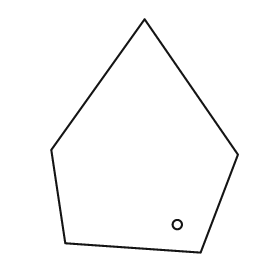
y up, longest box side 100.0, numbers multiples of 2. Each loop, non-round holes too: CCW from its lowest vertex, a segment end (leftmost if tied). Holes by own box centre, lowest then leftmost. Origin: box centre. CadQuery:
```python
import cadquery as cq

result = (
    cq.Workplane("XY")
    .moveTo(24.0, -50.0)
    .lineTo(40.0, -8.0)
    .lineTo(0.0, 50.0)
    .lineTo(-40.0, -6.0)
    .lineTo(-34.0, -46.0)
    .close()
    .moveTo(14.0, -38.0)
    .circle(2.0)
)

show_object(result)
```